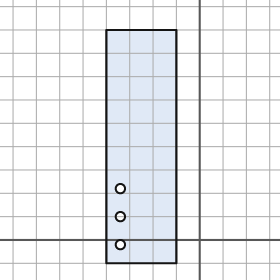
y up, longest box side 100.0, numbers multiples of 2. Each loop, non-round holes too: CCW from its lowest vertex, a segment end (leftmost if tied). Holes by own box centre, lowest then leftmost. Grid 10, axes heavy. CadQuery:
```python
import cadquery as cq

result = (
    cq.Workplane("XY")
    .moveTo(-40.0, -10.0)
    .lineTo(-10.0, -10.0)
    .lineTo(-10.0, 90.0)
    .lineTo(-40.0, 90.0)
    .close()
    .moveTo(-34.0, -2.0)
    .circle(2.0)
    .moveTo(-34.0, 10.0)
    .circle(2.0)
    .moveTo(-34.0, 22.0)
    .circle(2.0)
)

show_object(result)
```